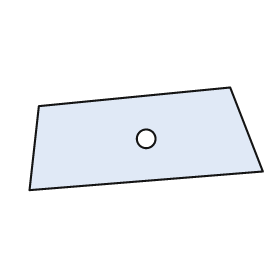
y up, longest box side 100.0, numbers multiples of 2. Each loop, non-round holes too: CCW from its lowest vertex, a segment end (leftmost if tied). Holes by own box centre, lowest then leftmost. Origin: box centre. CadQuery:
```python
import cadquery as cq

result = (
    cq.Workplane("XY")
    .moveTo(-50.0, -22.0)
    .lineTo(50.0, -14.0)
    .lineTo(36.0, 22.0)
    .lineTo(-46.0, 14.0)
    .close()
    .moveTo(0.0, 0.0)
    .circle(4.0)
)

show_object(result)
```